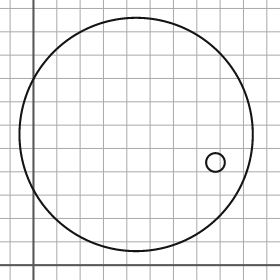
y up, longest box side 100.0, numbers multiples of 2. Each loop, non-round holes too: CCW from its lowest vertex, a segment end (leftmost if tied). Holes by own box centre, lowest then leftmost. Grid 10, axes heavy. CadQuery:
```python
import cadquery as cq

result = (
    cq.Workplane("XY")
    .moveTo(44.0, 56.0)
    .circle(50.0)
    .moveTo(78.0, 44.0)
    .circle(4.0)
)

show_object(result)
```